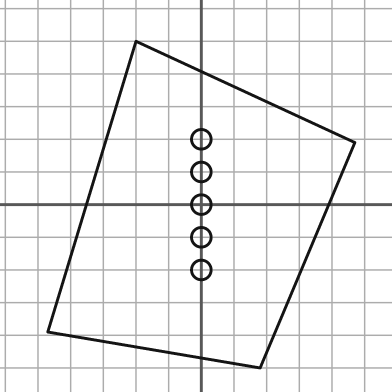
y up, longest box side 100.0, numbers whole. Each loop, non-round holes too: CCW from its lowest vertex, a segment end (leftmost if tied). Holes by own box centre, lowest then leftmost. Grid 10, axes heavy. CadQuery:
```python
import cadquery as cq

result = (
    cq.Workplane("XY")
    .moveTo(18.0, -50.0)
    .lineTo(47.0, 19.0)
    .lineTo(-20.0, 50.0)
    .lineTo(-47.0, -39.0)
    .close()
    .moveTo(0.0, -20.0)
    .circle(3.0)
    .moveTo(0.0, -10.0)
    .circle(3.0)
    .moveTo(0.0, 0.0)
    .circle(3.0)
    .moveTo(0.0, 10.0)
    .circle(3.0)
    .moveTo(0.0, 20.0)
    .circle(3.0)
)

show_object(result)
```